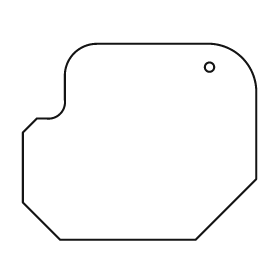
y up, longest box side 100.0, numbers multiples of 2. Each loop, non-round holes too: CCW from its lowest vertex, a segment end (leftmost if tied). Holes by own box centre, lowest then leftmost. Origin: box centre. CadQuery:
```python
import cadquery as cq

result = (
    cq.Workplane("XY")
    .moveTo(-34.0, -42.0)
    .lineTo(24.0, -42.0)
    .lineTo(50.0, -16.0)
    .lineTo(50.0, 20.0)
    .threePointArc((44.0, 36.0), (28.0, 42.0))
    .lineTo(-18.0, 42.0)
    .threePointArc((-28.0, 38.0), (-32.0, 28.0))
    .lineTo(-32.0, 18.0)
    .threePointArc((-34.0, 12.0), (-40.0, 10.0))
    .lineTo(-44.0, 10.0)
    .lineTo(-50.0, 4.0)
    .lineTo(-50.0, -26.0)
    .close()
    .moveTo(30.0, 32.0)
    .circle(2.0)
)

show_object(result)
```